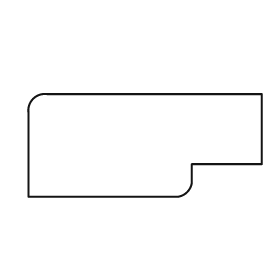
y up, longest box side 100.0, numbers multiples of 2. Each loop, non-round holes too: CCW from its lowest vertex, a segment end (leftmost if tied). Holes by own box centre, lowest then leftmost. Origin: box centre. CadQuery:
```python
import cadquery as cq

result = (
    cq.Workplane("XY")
    .moveTo(-50.0, -22.0)
    .lineTo(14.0, -22.0)
    .threePointArc((18.0, -20.0), (20.0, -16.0))
    .lineTo(20.0, -8.0)
    .lineTo(50.0, -8.0)
    .lineTo(50.0, 22.0)
    .lineTo(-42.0, 22.0)
    .threePointArc((-48.0, 20.0), (-50.0, 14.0))
    .close()
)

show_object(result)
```